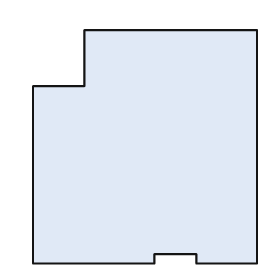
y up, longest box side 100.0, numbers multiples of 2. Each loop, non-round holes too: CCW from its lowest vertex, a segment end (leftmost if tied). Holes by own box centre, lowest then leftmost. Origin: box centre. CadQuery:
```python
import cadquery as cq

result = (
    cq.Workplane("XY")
    .moveTo(-48.0, -50.0)
    .lineTo(4.0, -50.0)
    .lineTo(4.0, -46.0)
    .lineTo(22.0, -46.0)
    .lineTo(22.0, -50.0)
    .lineTo(48.0, -50.0)
    .lineTo(48.0, 50.0)
    .lineTo(-26.0, 50.0)
    .lineTo(-26.0, 26.0)
    .lineTo(-48.0, 26.0)
    .close()
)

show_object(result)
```